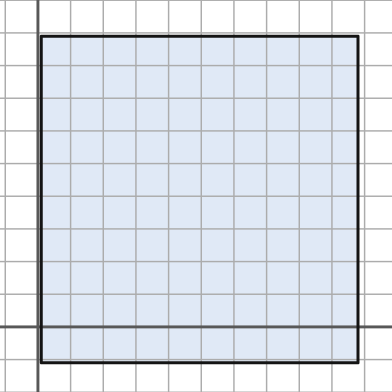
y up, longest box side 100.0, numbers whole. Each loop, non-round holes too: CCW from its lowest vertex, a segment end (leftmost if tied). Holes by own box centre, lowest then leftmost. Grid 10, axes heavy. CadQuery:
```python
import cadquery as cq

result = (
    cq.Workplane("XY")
    .moveTo(1.0, -11.0)
    .lineTo(98.0, -11.0)
    .lineTo(98.0, 89.0)
    .lineTo(1.0, 89.0)
    .close()
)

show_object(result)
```